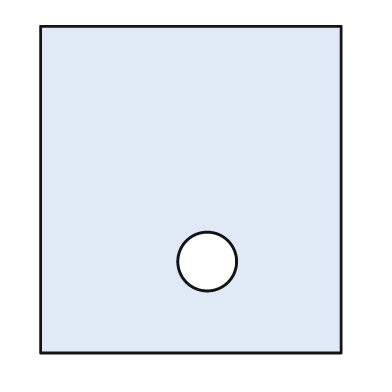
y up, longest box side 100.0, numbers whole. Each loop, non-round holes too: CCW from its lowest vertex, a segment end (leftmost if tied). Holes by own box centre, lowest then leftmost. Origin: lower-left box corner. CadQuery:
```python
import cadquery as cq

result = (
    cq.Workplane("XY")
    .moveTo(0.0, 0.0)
    .lineTo(92.0, 0.0)
    .lineTo(92.0, 100.0)
    .lineTo(0.0, 100.0)
    .close()
    .moveTo(51.0, 28.0)
    .circle(9.0)
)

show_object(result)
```